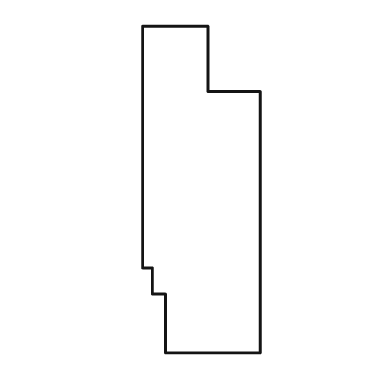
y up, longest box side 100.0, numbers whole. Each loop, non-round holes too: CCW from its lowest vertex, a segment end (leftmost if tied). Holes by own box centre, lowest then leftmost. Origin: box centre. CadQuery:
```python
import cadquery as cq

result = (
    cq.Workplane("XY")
    .moveTo(-11.0, -50.0)
    .lineTo(18.0, -50.0)
    .lineTo(18.0, 30.0)
    .lineTo(2.0, 30.0)
    .lineTo(2.0, 50.0)
    .lineTo(-18.0, 50.0)
    .lineTo(-18.0, -24.0)
    .lineTo(-15.0, -24.0)
    .lineTo(-15.0, -32.0)
    .lineTo(-11.0, -32.0)
    .close()
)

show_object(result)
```